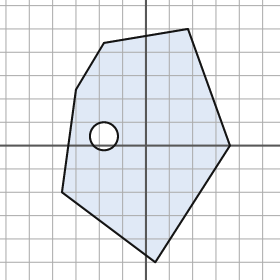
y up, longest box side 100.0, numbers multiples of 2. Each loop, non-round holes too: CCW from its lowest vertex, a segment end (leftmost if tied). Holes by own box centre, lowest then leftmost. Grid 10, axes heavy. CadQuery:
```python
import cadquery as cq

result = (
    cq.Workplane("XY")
    .moveTo(4.0, -50.0)
    .lineTo(36.0, 0.0)
    .lineTo(18.0, 50.0)
    .lineTo(-18.0, 44.0)
    .lineTo(-30.0, 24.0)
    .lineTo(-36.0, -20.0)
    .close()
    .moveTo(-18.0, 4.0)
    .circle(6.0)
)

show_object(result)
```